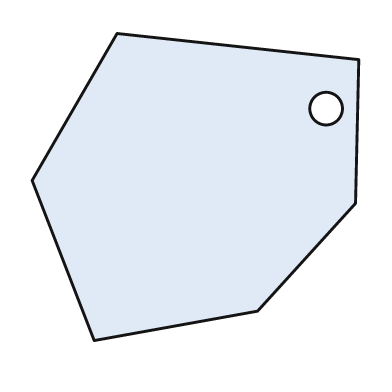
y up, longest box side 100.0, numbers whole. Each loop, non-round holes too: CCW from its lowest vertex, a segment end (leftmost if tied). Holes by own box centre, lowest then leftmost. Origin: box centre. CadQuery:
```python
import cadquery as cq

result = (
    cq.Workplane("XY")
    .moveTo(-31.0, -47.0)
    .lineTo(19.0, -38.0)
    .lineTo(49.0, -5.0)
    .lineTo(50.0, 39.0)
    .lineTo(-24.0, 47.0)
    .lineTo(-50.0, 2.0)
    .close()
    .moveTo(40.0, 24.0)
    .circle(5.0)
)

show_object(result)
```